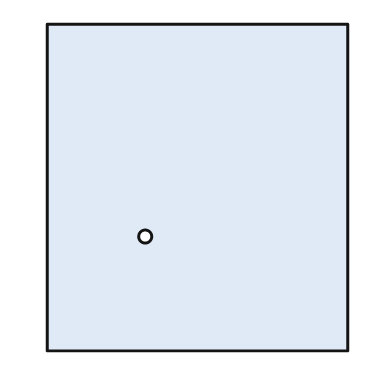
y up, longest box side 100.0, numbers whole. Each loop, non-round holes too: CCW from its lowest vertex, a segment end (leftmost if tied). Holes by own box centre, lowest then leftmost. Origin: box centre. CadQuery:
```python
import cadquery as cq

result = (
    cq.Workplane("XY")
    .moveTo(-46.0, -50.0)
    .lineTo(46.0, -50.0)
    .lineTo(46.0, 50.0)
    .lineTo(-46.0, 50.0)
    .close()
    .moveTo(-16.0, -15.0)
    .circle(2.0)
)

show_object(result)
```